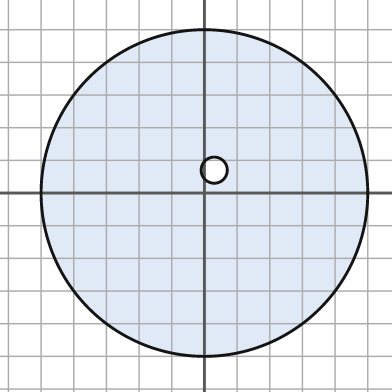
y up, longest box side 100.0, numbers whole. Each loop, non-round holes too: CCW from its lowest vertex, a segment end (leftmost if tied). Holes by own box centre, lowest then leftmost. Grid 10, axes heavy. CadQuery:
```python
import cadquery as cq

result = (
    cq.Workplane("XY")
    .moveTo(0.0, 0.0)
    .circle(50.0)
    .moveTo(3.0, 7.0)
    .circle(4.0)
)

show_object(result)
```